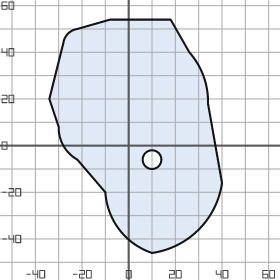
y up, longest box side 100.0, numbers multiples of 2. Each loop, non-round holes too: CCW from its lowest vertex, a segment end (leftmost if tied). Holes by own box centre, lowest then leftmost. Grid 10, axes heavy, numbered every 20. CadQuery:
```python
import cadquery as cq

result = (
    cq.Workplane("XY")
    .moveTo(10.0, -46.0)
    .threePointArc((30.0, -36.0), (40.0, -16.0))
    .lineTo(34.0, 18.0)
    .threePointArc((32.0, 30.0), (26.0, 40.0))
    .lineTo(18.0, 54.0)
    .lineTo(-8.0, 54.0)
    .lineTo(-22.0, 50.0)
    .threePointArc((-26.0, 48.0), (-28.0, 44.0))
    .lineTo(-34.0, 20.0)
    .lineTo(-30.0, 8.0)
    .threePointArc((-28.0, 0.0), (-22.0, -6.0))
    .lineTo(-10.0, -20.0)
    .threePointArc((-4.0, -36.0), (10.0, -46.0))
    .close()
    .moveTo(10.0, -6.0)
    .circle(4.0)
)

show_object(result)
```